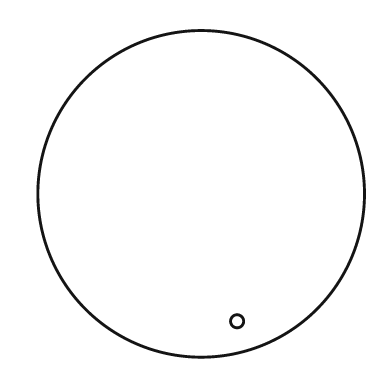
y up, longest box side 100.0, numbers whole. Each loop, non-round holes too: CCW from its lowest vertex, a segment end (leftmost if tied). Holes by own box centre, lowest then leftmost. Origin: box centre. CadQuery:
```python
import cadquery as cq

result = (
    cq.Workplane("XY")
    .moveTo(0.0, 0.0)
    .circle(50.0)
    .moveTo(11.0, -39.0)
    .circle(2.0)
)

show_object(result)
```